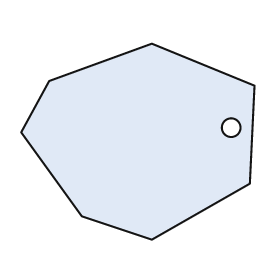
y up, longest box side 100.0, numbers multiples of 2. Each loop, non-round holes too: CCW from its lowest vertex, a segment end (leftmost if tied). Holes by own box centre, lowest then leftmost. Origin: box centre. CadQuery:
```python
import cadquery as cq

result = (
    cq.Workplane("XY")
    .moveTo(6.0, -42.0)
    .lineTo(48.0, -18.0)
    .lineTo(50.0, 24.0)
    .lineTo(6.0, 42.0)
    .lineTo(-38.0, 26.0)
    .lineTo(-50.0, 4.0)
    .lineTo(-24.0, -32.0)
    .close()
    .moveTo(40.0, 6.0)
    .circle(4.0)
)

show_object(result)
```